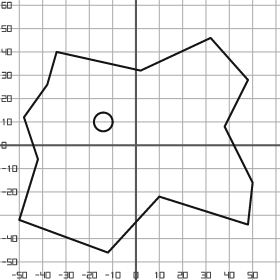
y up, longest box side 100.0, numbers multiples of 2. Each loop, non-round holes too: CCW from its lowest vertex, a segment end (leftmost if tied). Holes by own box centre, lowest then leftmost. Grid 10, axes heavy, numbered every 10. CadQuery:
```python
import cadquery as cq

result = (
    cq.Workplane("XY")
    .moveTo(-12.0, -46.0)
    .lineTo(10.0, -22.0)
    .lineTo(48.0, -34.0)
    .lineTo(50.0, -16.0)
    .lineTo(38.0, 8.0)
    .lineTo(48.0, 28.0)
    .lineTo(32.0, 46.0)
    .lineTo(2.0, 32.0)
    .lineTo(-34.0, 40.0)
    .lineTo(-38.0, 26.0)
    .lineTo(-48.0, 12.0)
    .lineTo(-42.0, -6.0)
    .lineTo(-50.0, -32.0)
    .close()
    .moveTo(-14.0, 10.0)
    .circle(4.0)
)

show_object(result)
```